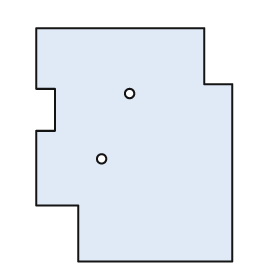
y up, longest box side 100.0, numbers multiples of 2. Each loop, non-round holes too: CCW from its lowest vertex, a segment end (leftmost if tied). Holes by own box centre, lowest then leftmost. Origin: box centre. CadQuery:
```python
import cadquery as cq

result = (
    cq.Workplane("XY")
    .moveTo(-24.0, -50.0)
    .lineTo(42.0, -50.0)
    .lineTo(42.0, 26.0)
    .lineTo(30.0, 26.0)
    .lineTo(30.0, 50.0)
    .lineTo(-42.0, 50.0)
    .lineTo(-42.0, 24.0)
    .lineTo(-34.0, 24.0)
    .lineTo(-34.0, 6.0)
    .lineTo(-42.0, 6.0)
    .lineTo(-42.0, -26.0)
    .lineTo(-24.0, -26.0)
    .close()
    .moveTo(-14.0, -6.0)
    .circle(2.0)
    .moveTo(-2.0, 22.0)
    .circle(2.0)
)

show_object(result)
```